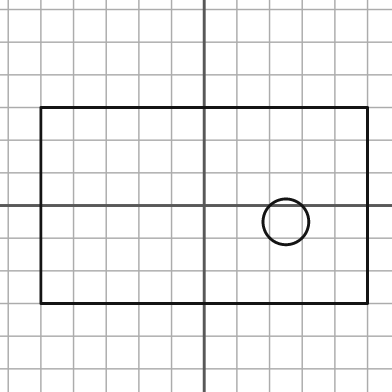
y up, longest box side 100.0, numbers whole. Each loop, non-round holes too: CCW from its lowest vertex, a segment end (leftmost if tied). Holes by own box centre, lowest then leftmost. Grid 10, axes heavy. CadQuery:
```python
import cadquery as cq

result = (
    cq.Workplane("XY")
    .moveTo(-50.0, -30.0)
    .lineTo(50.0, -30.0)
    .lineTo(50.0, 30.0)
    .lineTo(-50.0, 30.0)
    .close()
    .moveTo(25.0, -5.0)
    .circle(7.0)
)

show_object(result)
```